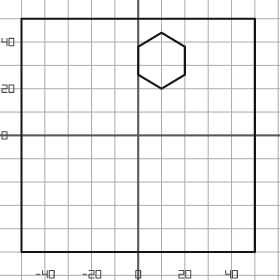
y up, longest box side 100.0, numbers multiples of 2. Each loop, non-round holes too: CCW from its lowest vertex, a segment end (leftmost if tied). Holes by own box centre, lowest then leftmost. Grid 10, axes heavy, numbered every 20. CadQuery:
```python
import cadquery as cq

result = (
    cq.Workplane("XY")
    .moveTo(-50.0, -50.0)
    .lineTo(50.0, -50.0)
    .lineTo(50.0, 50.0)
    .lineTo(-50.0, 50.0)
    .close()
    .moveTo(10.0, 20.0)
    .lineTo(20.0, 26.0)
    .lineTo(20.0, 38.0)
    .lineTo(10.0, 44.0)
    .lineTo(0.0, 38.0)
    .lineTo(0.0, 26.0)
    .close()
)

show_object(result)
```